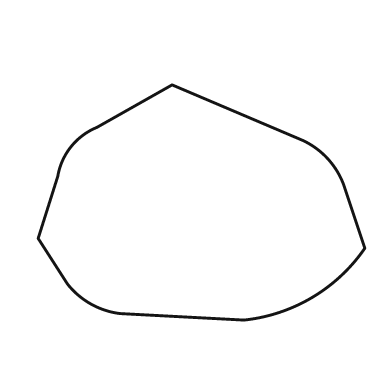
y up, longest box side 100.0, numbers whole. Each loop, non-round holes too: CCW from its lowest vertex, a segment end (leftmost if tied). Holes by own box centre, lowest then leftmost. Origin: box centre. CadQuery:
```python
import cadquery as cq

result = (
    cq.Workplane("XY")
    .moveTo(13.0, -36.0)
    .threePointArc((34.0, -29.0), (50.0, -14.0))
    .lineTo(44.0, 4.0)
    .threePointArc((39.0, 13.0), (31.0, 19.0))
    .lineTo(-9.0, 36.0)
    .lineTo(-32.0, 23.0)
    .threePointArc((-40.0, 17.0), (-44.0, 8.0))
    .lineTo(-50.0, -11.0)
    .lineTo(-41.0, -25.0)
    .threePointArc((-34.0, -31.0), (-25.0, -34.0))
    .close()
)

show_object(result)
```